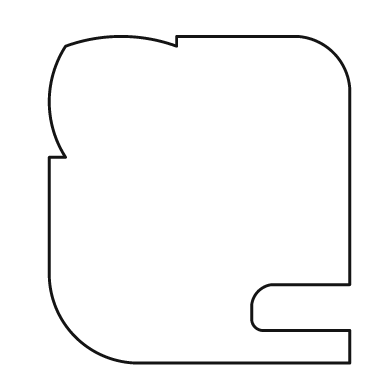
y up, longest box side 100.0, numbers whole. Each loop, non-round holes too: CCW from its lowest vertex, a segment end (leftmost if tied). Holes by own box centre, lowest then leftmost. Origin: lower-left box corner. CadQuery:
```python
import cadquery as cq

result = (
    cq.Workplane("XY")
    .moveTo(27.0, 0.0)
    .lineTo(92.0, 0.0)
    .lineTo(92.0, 10.0)
    .lineTo(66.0, 10.0)
    .threePointArc((63.0, 11.0), (62.0, 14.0))
    .lineTo(62.0, 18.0)
    .threePointArc((64.0, 22.0), (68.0, 24.0))
    .lineTo(92.0, 24.0)
    .lineTo(92.0, 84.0)
    .threePointArc((87.0, 95.0), (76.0, 100.0))
    .lineTo(39.0, 100.0)
    .lineTo(39.0, 97.0)
    .threePointArc((22.0, 100.0), (5.0, 97.0))
    .threePointArc((0.0, 80.0), (5.0, 63.0))
    .lineTo(0.0, 63.0)
    .lineTo(0.0, 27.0)
    .threePointArc((8.0, 8.0), (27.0, 0.0))
    .close()
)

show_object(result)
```